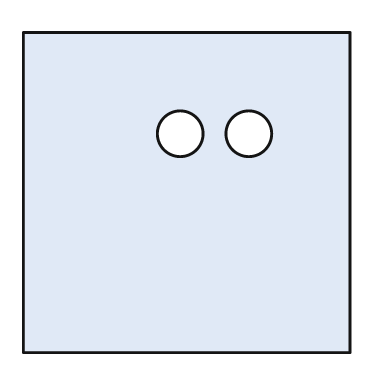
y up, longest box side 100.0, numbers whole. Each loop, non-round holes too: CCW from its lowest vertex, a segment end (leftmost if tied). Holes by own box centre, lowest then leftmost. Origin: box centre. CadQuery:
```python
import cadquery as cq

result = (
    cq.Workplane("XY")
    .moveTo(-50.0, -49.0)
    .lineTo(50.0, -49.0)
    .lineTo(50.0, 49.0)
    .lineTo(-50.0, 49.0)
    .close()
    .moveTo(-2.0, 18.0)
    .circle(7.0)
    .moveTo(19.0, 18.0)
    .circle(7.0)
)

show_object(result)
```